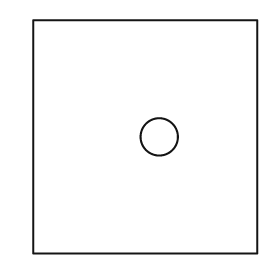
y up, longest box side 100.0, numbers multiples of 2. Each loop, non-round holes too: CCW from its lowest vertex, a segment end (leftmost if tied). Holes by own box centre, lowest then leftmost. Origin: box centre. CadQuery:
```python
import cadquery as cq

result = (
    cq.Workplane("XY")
    .moveTo(-48.0, -50.0)
    .lineTo(48.0, -50.0)
    .lineTo(48.0, 50.0)
    .lineTo(-48.0, 50.0)
    .close()
    .moveTo(6.0, 0.0)
    .circle(8.0)
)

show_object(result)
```